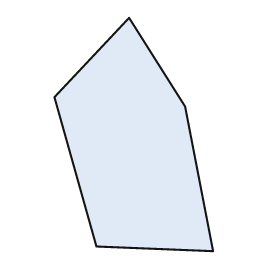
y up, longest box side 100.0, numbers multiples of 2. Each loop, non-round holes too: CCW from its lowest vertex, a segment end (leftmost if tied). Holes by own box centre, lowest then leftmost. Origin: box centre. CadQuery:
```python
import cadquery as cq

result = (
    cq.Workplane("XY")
    .moveTo(34.0, -50.0)
    .lineTo(22.0, 12.0)
    .lineTo(-2.0, 50.0)
    .lineTo(-34.0, 16.0)
    .lineTo(-16.0, -48.0)
    .close()
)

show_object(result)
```